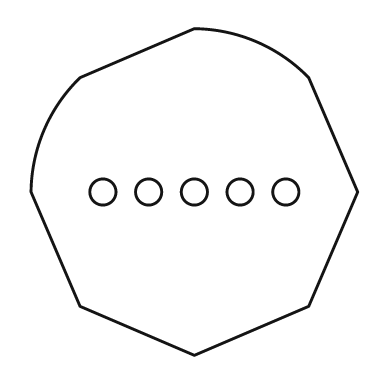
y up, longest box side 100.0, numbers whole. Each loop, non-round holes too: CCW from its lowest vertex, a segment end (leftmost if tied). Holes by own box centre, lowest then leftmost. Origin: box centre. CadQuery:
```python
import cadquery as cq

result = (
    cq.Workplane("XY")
    .moveTo(0.0, -50.0)
    .lineTo(35.0, -35.0)
    .lineTo(50.0, 0.0)
    .lineTo(35.0, 35.0)
    .threePointArc((19.0, 46.0), (0.0, 50.0))
    .lineTo(-35.0, 35.0)
    .threePointArc((-46.0, 19.0), (-50.0, 0.0))
    .lineTo(-35.0, -35.0)
    .close()
    .moveTo(-28.0, 0.0)
    .circle(4.0)
    .moveTo(-14.0, 0.0)
    .circle(4.0)
    .moveTo(0.0, 0.0)
    .circle(4.0)
    .moveTo(14.0, 0.0)
    .circle(4.0)
    .moveTo(28.0, 0.0)
    .circle(4.0)
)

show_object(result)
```